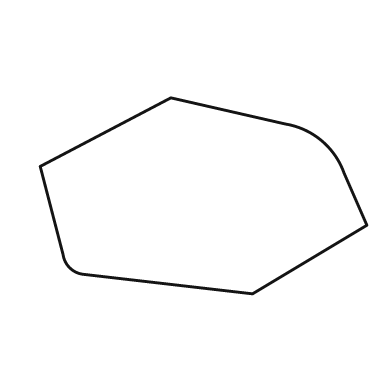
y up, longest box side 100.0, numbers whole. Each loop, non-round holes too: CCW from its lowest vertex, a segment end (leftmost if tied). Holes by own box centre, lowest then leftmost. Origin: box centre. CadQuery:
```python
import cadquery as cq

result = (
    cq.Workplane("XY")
    .moveTo(15.0, -30.0)
    .lineTo(50.0, -9.0)
    .lineTo(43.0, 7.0)
    .threePointArc((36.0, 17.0), (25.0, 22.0))
    .lineTo(-10.0, 30.0)
    .lineTo(-50.0, 9.0)
    .lineTo(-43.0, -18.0)
    .threePointArc((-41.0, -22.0), (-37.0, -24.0))
    .close()
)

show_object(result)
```